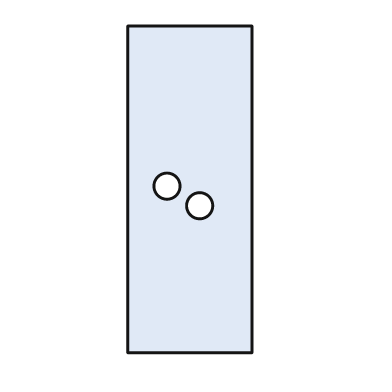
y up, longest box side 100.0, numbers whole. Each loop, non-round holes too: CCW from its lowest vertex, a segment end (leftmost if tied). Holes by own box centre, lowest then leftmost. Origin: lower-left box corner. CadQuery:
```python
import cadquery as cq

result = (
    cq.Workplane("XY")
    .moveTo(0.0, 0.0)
    .lineTo(38.0, 0.0)
    .lineTo(38.0, 100.0)
    .lineTo(0.0, 100.0)
    .close()
    .moveTo(22.0, 45.0)
    .circle(4.0)
    .moveTo(12.0, 51.0)
    .circle(4.0)
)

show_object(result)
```